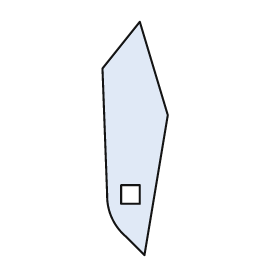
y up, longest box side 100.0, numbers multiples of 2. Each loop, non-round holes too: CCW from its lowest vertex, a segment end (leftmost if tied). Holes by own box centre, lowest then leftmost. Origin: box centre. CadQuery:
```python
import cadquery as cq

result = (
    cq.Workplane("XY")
    .moveTo(4.0, -50.0)
    .lineTo(14.0, 10.0)
    .lineTo(2.0, 50.0)
    .lineTo(-14.0, 30.0)
    .lineTo(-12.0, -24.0)
    .threePointArc((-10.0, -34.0), (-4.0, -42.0))
    .close()
    .moveTo(-6.0, -28.0)
    .lineTo(2.0, -28.0)
    .lineTo(2.0, -20.0)
    .lineTo(-6.0, -20.0)
    .close()
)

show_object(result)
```